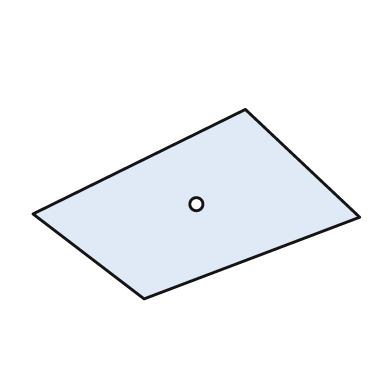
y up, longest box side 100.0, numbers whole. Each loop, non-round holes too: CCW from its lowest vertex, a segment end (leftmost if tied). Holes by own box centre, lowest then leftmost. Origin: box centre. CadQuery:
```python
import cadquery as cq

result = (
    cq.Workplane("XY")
    .moveTo(-16.0, -29.0)
    .lineTo(50.0, -4.0)
    .lineTo(15.0, 29.0)
    .lineTo(-50.0, -3.0)
    .close()
    .moveTo(0.0, 0.0)
    .circle(2.0)
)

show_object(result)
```